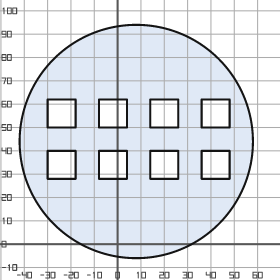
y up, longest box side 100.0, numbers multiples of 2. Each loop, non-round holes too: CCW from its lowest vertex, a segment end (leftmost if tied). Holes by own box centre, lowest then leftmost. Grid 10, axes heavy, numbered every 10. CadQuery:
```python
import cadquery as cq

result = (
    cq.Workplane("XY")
    .moveTo(8.0, 44.0)
    .circle(50.0)
    .moveTo(-30.0, 28.0)
    .lineTo(-18.0, 28.0)
    .lineTo(-18.0, 40.0)
    .lineTo(-30.0, 40.0)
    .close()
    .moveTo(-8.0, 28.0)
    .lineTo(4.0, 28.0)
    .lineTo(4.0, 40.0)
    .lineTo(-8.0, 40.0)
    .close()
    .moveTo(14.0, 28.0)
    .lineTo(26.0, 28.0)
    .lineTo(26.0, 40.0)
    .lineTo(14.0, 40.0)
    .close()
    .moveTo(36.0, 28.0)
    .lineTo(48.0, 28.0)
    .lineTo(48.0, 40.0)
    .lineTo(36.0, 40.0)
    .close()
    .moveTo(-30.0, 50.0)
    .lineTo(-18.0, 50.0)
    .lineTo(-18.0, 62.0)
    .lineTo(-30.0, 62.0)
    .close()
    .moveTo(-8.0, 50.0)
    .lineTo(4.0, 50.0)
    .lineTo(4.0, 62.0)
    .lineTo(-8.0, 62.0)
    .close()
    .moveTo(14.0, 50.0)
    .lineTo(26.0, 50.0)
    .lineTo(26.0, 62.0)
    .lineTo(14.0, 62.0)
    .close()
    .moveTo(36.0, 50.0)
    .lineTo(48.0, 50.0)
    .lineTo(48.0, 62.0)
    .lineTo(36.0, 62.0)
    .close()
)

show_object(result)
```